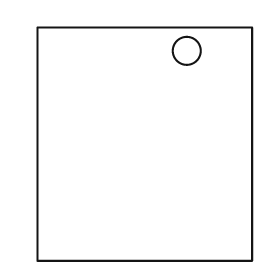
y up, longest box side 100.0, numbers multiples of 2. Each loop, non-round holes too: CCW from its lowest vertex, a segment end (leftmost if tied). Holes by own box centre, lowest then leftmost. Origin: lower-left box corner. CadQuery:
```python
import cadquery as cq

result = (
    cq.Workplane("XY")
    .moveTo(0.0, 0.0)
    .lineTo(92.0, 0.0)
    .lineTo(92.0, 100.0)
    .lineTo(0.0, 100.0)
    .close()
    .moveTo(64.0, 90.0)
    .circle(6.0)
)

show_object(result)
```